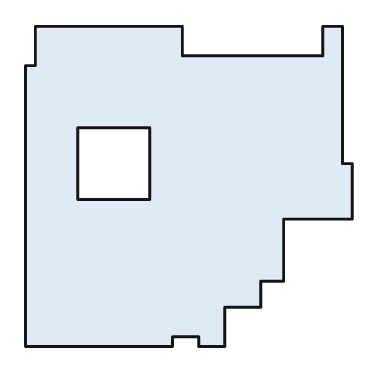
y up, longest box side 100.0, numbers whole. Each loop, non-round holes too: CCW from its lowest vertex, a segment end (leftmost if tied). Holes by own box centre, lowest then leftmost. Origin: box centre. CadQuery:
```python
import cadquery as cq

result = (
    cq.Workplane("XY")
    .moveTo(-50.0, -49.0)
    .lineTo(-5.0, -49.0)
    .lineTo(-5.0, -46.0)
    .lineTo(3.0, -46.0)
    .lineTo(3.0, -49.0)
    .lineTo(11.0, -49.0)
    .lineTo(11.0, -37.0)
    .lineTo(22.0, -37.0)
    .lineTo(22.0, -29.0)
    .lineTo(29.0, -29.0)
    .lineTo(29.0, -10.0)
    .lineTo(50.0, -10.0)
    .lineTo(50.0, 7.0)
    .lineTo(47.0, 7.0)
    .lineTo(47.0, 49.0)
    .lineTo(41.0, 49.0)
    .lineTo(41.0, 40.0)
    .lineTo(-2.0, 40.0)
    .lineTo(-2.0, 49.0)
    .lineTo(-47.0, 49.0)
    .lineTo(-47.0, 37.0)
    .lineTo(-50.0, 37.0)
    .close()
    .moveTo(-34.0, -4.0)
    .lineTo(-12.0, -4.0)
    .lineTo(-12.0, 18.0)
    .lineTo(-34.0, 18.0)
    .close()
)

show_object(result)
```